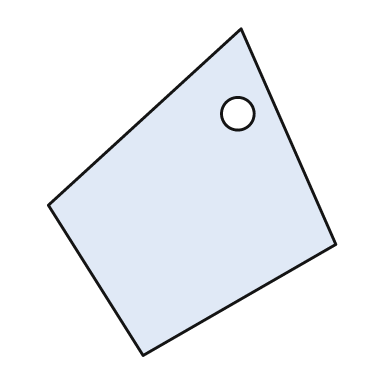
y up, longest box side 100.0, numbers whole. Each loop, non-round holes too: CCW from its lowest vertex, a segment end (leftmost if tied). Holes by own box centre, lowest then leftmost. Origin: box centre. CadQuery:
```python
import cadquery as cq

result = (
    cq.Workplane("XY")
    .moveTo(-15.0, -50.0)
    .lineTo(44.0, -16.0)
    .lineTo(15.0, 50.0)
    .lineTo(-44.0, -4.0)
    .close()
    .moveTo(14.0, 24.0)
    .circle(5.0)
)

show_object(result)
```